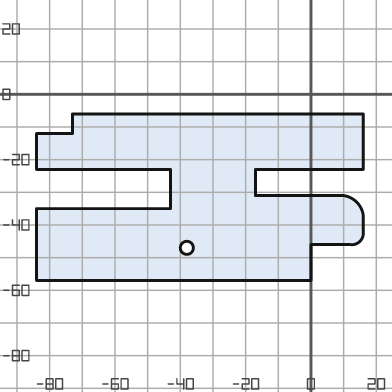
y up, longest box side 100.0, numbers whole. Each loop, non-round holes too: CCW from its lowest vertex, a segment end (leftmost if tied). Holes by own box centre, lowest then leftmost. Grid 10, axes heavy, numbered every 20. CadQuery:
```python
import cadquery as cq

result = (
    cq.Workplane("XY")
    .moveTo(-84.0, -57.0)
    .lineTo(0.0, -57.0)
    .lineTo(0.0, -46.0)
    .lineTo(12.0, -46.0)
    .threePointArc((15.0, -45.0), (16.0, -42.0))
    .lineTo(16.0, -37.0)
    .threePointArc((14.0, -33.0), (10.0, -31.0))
    .lineTo(-17.0, -31.0)
    .lineTo(-17.0, -23.0)
    .lineTo(16.0, -23.0)
    .lineTo(16.0, -6.0)
    .lineTo(-73.0, -6.0)
    .lineTo(-73.0, -12.0)
    .lineTo(-84.0, -12.0)
    .lineTo(-84.0, -23.0)
    .lineTo(-43.0, -23.0)
    .lineTo(-43.0, -35.0)
    .lineTo(-84.0, -35.0)
    .close()
    .moveTo(-38.0, -47.0)
    .circle(2.0)
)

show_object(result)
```